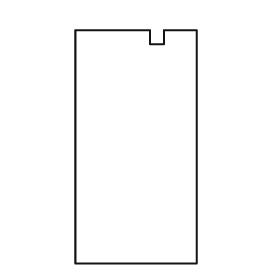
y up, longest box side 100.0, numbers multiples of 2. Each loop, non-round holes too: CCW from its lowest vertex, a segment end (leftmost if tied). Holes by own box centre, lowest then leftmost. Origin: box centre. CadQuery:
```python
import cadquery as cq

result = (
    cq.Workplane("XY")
    .moveTo(-26.0, -50.0)
    .lineTo(26.0, -50.0)
    .lineTo(26.0, 50.0)
    .lineTo(12.0, 50.0)
    .lineTo(12.0, 44.0)
    .lineTo(6.0, 44.0)
    .lineTo(6.0, 50.0)
    .lineTo(-26.0, 50.0)
    .close()
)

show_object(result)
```